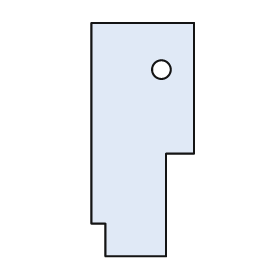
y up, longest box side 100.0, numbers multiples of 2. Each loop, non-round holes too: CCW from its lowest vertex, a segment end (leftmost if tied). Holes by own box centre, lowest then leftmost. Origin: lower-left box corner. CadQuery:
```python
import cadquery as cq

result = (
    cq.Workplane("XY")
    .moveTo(6.0, 0.0)
    .lineTo(32.0, 0.0)
    .lineTo(32.0, 44.0)
    .lineTo(44.0, 44.0)
    .lineTo(44.0, 100.0)
    .lineTo(0.0, 100.0)
    .lineTo(0.0, 14.0)
    .lineTo(6.0, 14.0)
    .close()
    .moveTo(30.0, 80.0)
    .circle(4.0)
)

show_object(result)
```